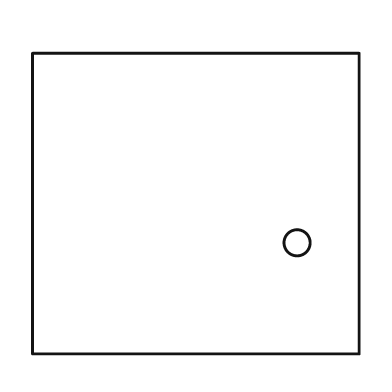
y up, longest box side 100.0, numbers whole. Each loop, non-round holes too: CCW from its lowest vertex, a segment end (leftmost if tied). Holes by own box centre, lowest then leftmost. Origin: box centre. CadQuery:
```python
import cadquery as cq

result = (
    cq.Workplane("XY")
    .moveTo(-50.0, -46.0)
    .lineTo(50.0, -46.0)
    .lineTo(50.0, 46.0)
    .lineTo(-50.0, 46.0)
    .close()
    .moveTo(31.0, -12.0)
    .circle(4.0)
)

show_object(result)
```